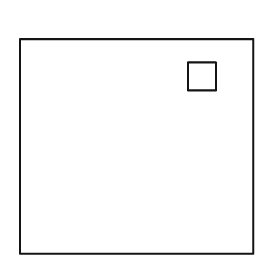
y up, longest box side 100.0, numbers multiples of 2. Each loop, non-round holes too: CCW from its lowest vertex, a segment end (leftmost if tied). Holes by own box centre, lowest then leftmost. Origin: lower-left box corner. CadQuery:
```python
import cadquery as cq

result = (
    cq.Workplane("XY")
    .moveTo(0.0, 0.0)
    .lineTo(100.0, 0.0)
    .lineTo(100.0, 92.0)
    .lineTo(0.0, 92.0)
    .close()
    .moveTo(72.0, 70.0)
    .lineTo(84.0, 70.0)
    .lineTo(84.0, 82.0)
    .lineTo(72.0, 82.0)
    .close()
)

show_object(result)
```